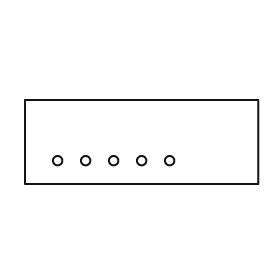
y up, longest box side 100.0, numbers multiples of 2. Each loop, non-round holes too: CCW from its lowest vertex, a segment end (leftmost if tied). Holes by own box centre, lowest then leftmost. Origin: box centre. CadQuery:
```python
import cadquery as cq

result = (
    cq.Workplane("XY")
    .moveTo(-50.0, -18.0)
    .lineTo(50.0, -18.0)
    .lineTo(50.0, 18.0)
    .lineTo(-50.0, 18.0)
    .close()
    .moveTo(-36.0, -8.0)
    .circle(2.0)
    .moveTo(-24.0, -8.0)
    .circle(2.0)
    .moveTo(-12.0, -8.0)
    .circle(2.0)
    .moveTo(0.0, -8.0)
    .circle(2.0)
    .moveTo(12.0, -8.0)
    .circle(2.0)
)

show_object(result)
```